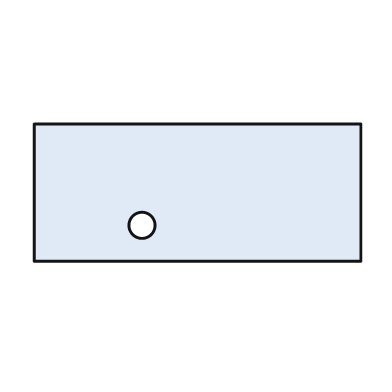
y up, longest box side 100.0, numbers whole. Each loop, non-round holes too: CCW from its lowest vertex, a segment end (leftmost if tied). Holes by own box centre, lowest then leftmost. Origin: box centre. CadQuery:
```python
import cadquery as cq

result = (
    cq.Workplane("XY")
    .moveTo(-50.0, -21.0)
    .lineTo(50.0, -21.0)
    .lineTo(50.0, 21.0)
    .lineTo(-50.0, 21.0)
    .close()
    .moveTo(-17.0, -10.0)
    .circle(4.0)
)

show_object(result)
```